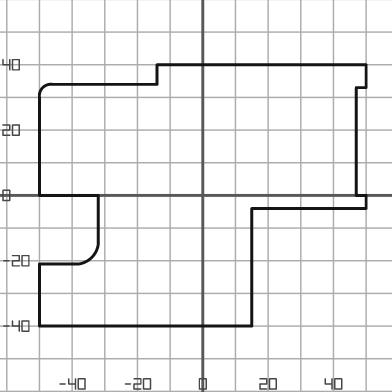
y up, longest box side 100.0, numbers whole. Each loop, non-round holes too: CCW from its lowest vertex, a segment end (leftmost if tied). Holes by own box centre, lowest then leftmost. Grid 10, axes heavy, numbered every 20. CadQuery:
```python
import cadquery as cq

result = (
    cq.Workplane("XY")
    .moveTo(-50.0, -40.0)
    .lineTo(15.0, -40.0)
    .lineTo(15.0, -4.0)
    .lineTo(50.0, -4.0)
    .lineTo(50.0, 0.0)
    .lineTo(47.0, 0.0)
    .lineTo(47.0, 33.0)
    .lineTo(50.0, 33.0)
    .lineTo(50.0, 40.0)
    .lineTo(-14.0, 40.0)
    .lineTo(-14.0, 34.0)
    .lineTo(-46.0, 34.0)
    .threePointArc((-49.0, 33.0), (-50.0, 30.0))
    .lineTo(-50.0, 0.0)
    .lineTo(-32.0, 0.0)
    .lineTo(-32.0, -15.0)
    .threePointArc((-34.0, -19.0), (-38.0, -21.0))
    .lineTo(-50.0, -21.0)
    .close()
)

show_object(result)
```